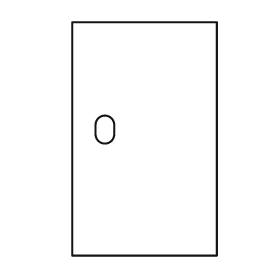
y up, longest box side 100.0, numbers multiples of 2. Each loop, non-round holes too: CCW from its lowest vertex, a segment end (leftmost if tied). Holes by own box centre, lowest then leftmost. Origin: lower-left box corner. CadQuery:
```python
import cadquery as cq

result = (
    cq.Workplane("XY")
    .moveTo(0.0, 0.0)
    .lineTo(62.0, 0.0)
    .lineTo(62.0, 100.0)
    .lineTo(0.0, 100.0)
    .close()
    .moveTo(10.0, 52.0)
    .threePointArc((14.0, 48.0), (18.0, 52.0))
    .lineTo(18.0, 56.0)
    .threePointArc((14.0, 60.0), (10.0, 56.0))
    .close()
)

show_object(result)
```